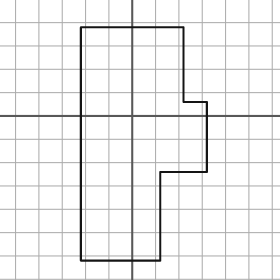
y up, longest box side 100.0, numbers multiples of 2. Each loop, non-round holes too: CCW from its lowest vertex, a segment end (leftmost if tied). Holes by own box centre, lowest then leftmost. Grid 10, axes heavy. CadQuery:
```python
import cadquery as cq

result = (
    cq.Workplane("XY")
    .moveTo(-22.0, -62.0)
    .lineTo(12.0, -62.0)
    .lineTo(12.0, -24.0)
    .lineTo(32.0, -24.0)
    .lineTo(32.0, 6.0)
    .lineTo(22.0, 6.0)
    .lineTo(22.0, 38.0)
    .lineTo(-22.0, 38.0)
    .close()
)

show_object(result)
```